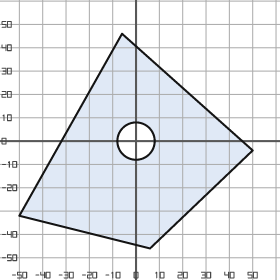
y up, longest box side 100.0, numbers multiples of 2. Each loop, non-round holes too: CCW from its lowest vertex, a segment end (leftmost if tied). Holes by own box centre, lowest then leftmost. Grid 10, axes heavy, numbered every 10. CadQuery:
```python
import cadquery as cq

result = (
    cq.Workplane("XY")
    .moveTo(6.0, -46.0)
    .lineTo(50.0, -4.0)
    .lineTo(-6.0, 46.0)
    .lineTo(-50.0, -32.0)
    .close()
    .moveTo(0.0, 0.0)
    .circle(8.0)
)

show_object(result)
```